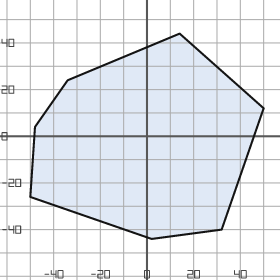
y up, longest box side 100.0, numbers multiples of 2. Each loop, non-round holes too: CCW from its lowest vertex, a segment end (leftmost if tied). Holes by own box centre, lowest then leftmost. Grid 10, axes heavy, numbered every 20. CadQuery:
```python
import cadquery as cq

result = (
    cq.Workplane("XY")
    .moveTo(2.0, -44.0)
    .lineTo(32.0, -40.0)
    .lineTo(50.0, 12.0)
    .lineTo(14.0, 44.0)
    .lineTo(-34.0, 24.0)
    .lineTo(-48.0, 4.0)
    .lineTo(-50.0, -26.0)
    .close()
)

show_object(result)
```